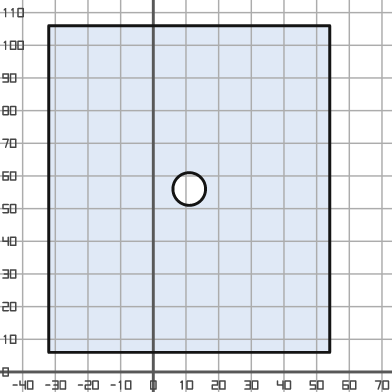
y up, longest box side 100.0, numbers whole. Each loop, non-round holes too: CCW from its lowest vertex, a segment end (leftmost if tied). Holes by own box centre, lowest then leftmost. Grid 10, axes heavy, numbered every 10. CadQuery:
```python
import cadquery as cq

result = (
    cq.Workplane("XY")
    .moveTo(-32.0, 6.0)
    .lineTo(54.0, 6.0)
    .lineTo(54.0, 106.0)
    .lineTo(-32.0, 106.0)
    .close()
    .moveTo(11.0, 56.0)
    .circle(5.0)
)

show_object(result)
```